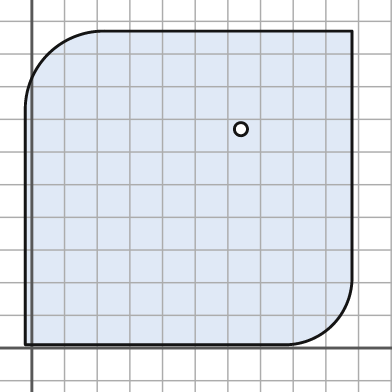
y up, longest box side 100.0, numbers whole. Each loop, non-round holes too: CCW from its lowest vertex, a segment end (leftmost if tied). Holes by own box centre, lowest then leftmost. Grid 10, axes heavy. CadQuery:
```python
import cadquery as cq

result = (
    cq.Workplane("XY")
    .moveTo(-2.0, 1.0)
    .lineTo(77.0, 1.0)
    .threePointArc((92.0, 7.0), (98.0, 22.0))
    .lineTo(98.0, 97.0)
    .lineTo(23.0, 97.0)
    .threePointArc((5.0, 90.0), (-2.0, 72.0))
    .close()
    .moveTo(64.0, 67.0)
    .circle(2.0)
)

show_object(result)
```